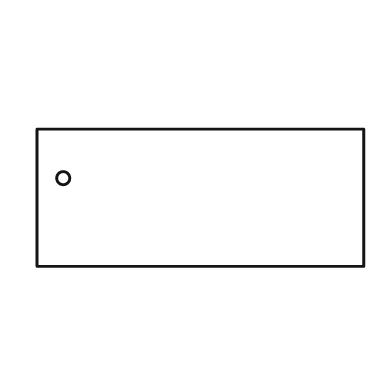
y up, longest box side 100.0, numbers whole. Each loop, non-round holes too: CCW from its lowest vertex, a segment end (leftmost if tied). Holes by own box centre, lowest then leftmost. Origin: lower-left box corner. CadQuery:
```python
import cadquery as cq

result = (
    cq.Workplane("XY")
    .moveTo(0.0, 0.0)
    .lineTo(100.0, 0.0)
    .lineTo(100.0, 42.0)
    .lineTo(0.0, 42.0)
    .close()
    .moveTo(8.0, 27.0)
    .circle(2.0)
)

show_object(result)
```